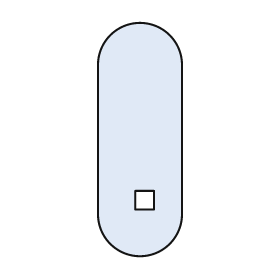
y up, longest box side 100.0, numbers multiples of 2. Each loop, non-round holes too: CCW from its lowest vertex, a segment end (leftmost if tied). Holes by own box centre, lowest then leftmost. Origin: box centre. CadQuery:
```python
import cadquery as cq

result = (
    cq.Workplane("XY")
    .moveTo(-18.0, -32.0)
    .threePointArc((0.0, -50.0), (18.0, -32.0))
    .lineTo(18.0, 32.0)
    .threePointArc((0.0, 50.0), (-18.0, 32.0))
    .close()
    .moveTo(-2.0, -30.0)
    .lineTo(6.0, -30.0)
    .lineTo(6.0, -22.0)
    .lineTo(-2.0, -22.0)
    .close()
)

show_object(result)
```